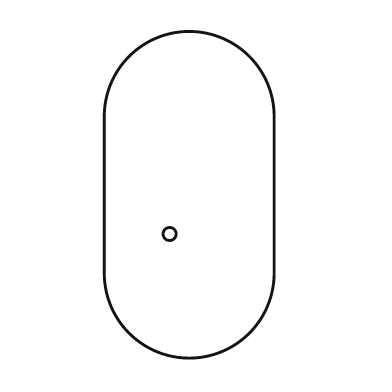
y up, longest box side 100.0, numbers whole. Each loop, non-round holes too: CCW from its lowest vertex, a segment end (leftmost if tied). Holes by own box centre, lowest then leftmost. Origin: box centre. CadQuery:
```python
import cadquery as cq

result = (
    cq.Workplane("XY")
    .moveTo(-26.0, -24.0)
    .threePointArc((0.0, -50.0), (26.0, -24.0))
    .lineTo(26.0, 24.0)
    .threePointArc((0.0, 50.0), (-26.0, 24.0))
    .close()
    .moveTo(-6.0, -12.0)
    .circle(2.0)
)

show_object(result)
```